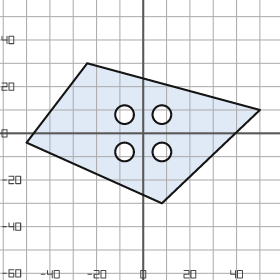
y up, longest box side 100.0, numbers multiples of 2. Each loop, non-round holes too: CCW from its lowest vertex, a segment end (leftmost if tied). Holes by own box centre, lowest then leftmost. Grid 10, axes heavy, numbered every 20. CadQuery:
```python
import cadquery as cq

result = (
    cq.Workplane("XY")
    .moveTo(8.0, -30.0)
    .lineTo(50.0, 10.0)
    .lineTo(-24.0, 30.0)
    .lineTo(-50.0, -4.0)
    .close()
    .moveTo(-8.0, -8.0)
    .circle(4.0)
    .moveTo(8.0, -8.0)
    .circle(4.0)
    .moveTo(-8.0, 8.0)
    .circle(4.0)
    .moveTo(8.0, 8.0)
    .circle(4.0)
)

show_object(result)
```